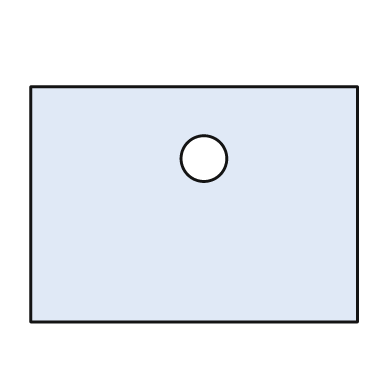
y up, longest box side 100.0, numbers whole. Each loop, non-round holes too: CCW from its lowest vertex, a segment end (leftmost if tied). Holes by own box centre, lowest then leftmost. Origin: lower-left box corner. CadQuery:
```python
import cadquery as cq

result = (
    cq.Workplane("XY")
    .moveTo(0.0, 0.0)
    .lineTo(100.0, 0.0)
    .lineTo(100.0, 72.0)
    .lineTo(0.0, 72.0)
    .close()
    .moveTo(53.0, 50.0)
    .circle(7.0)
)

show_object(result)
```